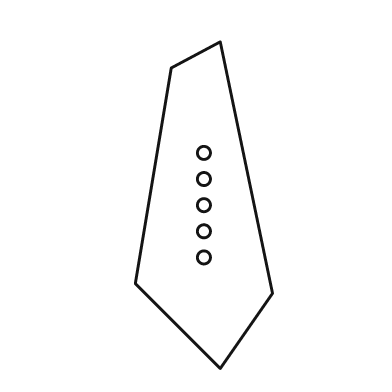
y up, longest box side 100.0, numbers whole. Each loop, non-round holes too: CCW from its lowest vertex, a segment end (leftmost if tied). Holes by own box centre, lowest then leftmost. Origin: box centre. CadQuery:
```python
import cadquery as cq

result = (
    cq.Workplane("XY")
    .moveTo(5.0, -50.0)
    .lineTo(21.0, -27.0)
    .lineTo(5.0, 50.0)
    .lineTo(-10.0, 42.0)
    .lineTo(-21.0, -24.0)
    .close()
    .moveTo(0.0, -16.0)
    .circle(2.0)
    .moveTo(0.0, -8.0)
    .circle(2.0)
    .moveTo(0.0, 0.0)
    .circle(2.0)
    .moveTo(0.0, 8.0)
    .circle(2.0)
    .moveTo(0.0, 16.0)
    .circle(2.0)
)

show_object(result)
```